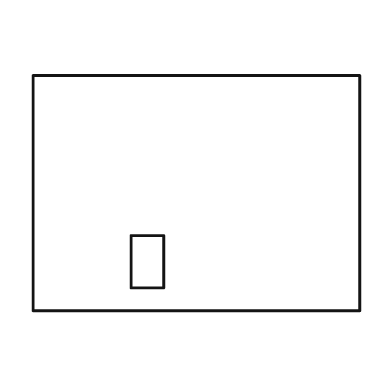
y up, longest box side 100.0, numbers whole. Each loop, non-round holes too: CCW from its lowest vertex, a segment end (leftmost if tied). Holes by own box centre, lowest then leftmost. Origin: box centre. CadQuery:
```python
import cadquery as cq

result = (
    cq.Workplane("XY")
    .moveTo(-50.0, -36.0)
    .lineTo(50.0, -36.0)
    .lineTo(50.0, 36.0)
    .lineTo(-50.0, 36.0)
    .close()
    .moveTo(-20.0, -29.0)
    .lineTo(-10.0, -29.0)
    .lineTo(-10.0, -13.0)
    .lineTo(-20.0, -13.0)
    .close()
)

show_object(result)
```